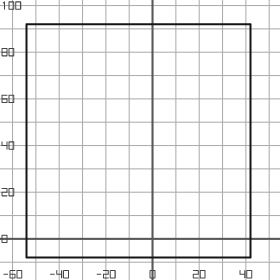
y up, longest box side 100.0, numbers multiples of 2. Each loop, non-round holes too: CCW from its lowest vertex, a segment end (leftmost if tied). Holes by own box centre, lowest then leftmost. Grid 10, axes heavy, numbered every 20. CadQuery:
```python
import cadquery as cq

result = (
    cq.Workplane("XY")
    .moveTo(-54.0, -8.0)
    .lineTo(42.0, -8.0)
    .lineTo(42.0, 92.0)
    .lineTo(-54.0, 92.0)
    .close()
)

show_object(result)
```